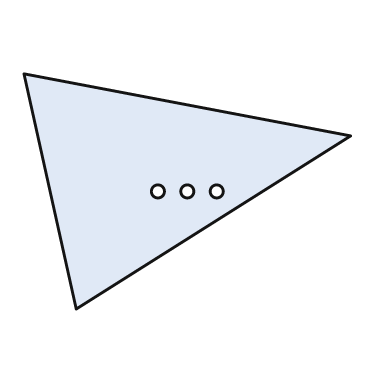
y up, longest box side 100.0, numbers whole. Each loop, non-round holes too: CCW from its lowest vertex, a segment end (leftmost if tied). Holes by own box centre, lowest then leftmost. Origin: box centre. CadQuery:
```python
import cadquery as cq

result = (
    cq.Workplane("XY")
    .moveTo(-34.0, -36.0)
    .lineTo(50.0, 17.0)
    .lineTo(-50.0, 36.0)
    .close()
    .moveTo(-9.0, 0.0)
    .circle(2.0)
    .moveTo(0.0, 0.0)
    .circle(2.0)
    .moveTo(9.0, 0.0)
    .circle(2.0)
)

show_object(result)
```